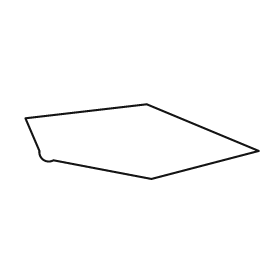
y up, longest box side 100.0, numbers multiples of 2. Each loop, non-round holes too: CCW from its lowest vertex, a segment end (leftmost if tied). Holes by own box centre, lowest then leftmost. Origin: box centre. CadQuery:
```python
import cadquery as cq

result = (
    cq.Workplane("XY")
    .moveTo(4.0, -16.0)
    .lineTo(50.0, -4.0)
    .lineTo(2.0, 16.0)
    .lineTo(-50.0, 10.0)
    .lineTo(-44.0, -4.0)
    .threePointArc((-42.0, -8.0), (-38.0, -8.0))
    .close()
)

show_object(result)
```